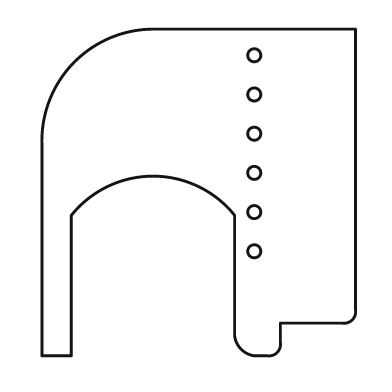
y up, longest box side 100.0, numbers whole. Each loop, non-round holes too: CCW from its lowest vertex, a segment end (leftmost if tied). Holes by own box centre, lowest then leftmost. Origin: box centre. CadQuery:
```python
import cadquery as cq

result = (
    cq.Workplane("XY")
    .moveTo(-48.0, -50.0)
    .lineTo(-39.0, -50.0)
    .lineTo(-39.0, -7.0)
    .threePointArc((-14.0, 5.0), (11.0, -7.0))
    .lineTo(11.0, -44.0)
    .threePointArc((13.0, -48.0), (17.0, -50.0))
    .lineTo(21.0, -50.0)
    .threePointArc((24.0, -49.0), (25.0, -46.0))
    .lineTo(25.0, -40.0)
    .lineTo(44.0, -40.0)
    .threePointArc((47.0, -39.0), (48.0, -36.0))
    .lineTo(48.0, 50.0)
    .lineTo(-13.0, 50.0)
    .threePointArc((-38.0, 40.0), (-48.0, 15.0))
    .close()
    .moveTo(17.0, -18.0)
    .circle(2.0)
    .moveTo(17.0, -6.0)
    .circle(2.0)
    .moveTo(17.0, 6.0)
    .circle(2.0)
    .moveTo(17.0, 18.0)
    .circle(2.0)
    .moveTo(17.0, 30.0)
    .circle(2.0)
    .moveTo(17.0, 42.0)
    .circle(2.0)
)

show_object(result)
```